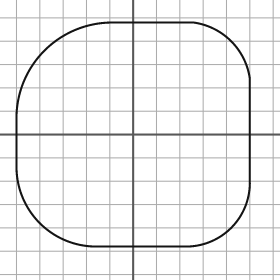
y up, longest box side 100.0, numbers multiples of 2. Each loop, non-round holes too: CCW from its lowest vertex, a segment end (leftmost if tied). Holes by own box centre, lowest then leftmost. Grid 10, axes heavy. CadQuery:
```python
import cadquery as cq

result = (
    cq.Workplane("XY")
    .moveTo(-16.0, -48.0)
    .lineTo(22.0, -48.0)
    .threePointArc((42.0, -40.0), (50.0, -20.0))
    .lineTo(50.0, 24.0)
    .threePointArc((42.0, 40.0), (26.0, 48.0))
    .lineTo(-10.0, 48.0)
    .threePointArc((-38.0, 36.0), (-50.0, 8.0))
    .lineTo(-50.0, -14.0)
    .threePointArc((-40.0, -38.0), (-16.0, -48.0))
    .close()
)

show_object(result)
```